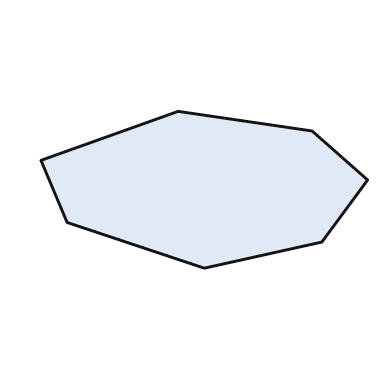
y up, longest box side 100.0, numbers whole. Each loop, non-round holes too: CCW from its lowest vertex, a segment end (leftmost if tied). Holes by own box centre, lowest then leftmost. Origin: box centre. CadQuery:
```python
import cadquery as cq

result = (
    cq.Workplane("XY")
    .moveTo(0.0, -24.0)
    .lineTo(36.0, -16.0)
    .lineTo(50.0, 3.0)
    .lineTo(33.0, 18.0)
    .lineTo(-8.0, 24.0)
    .lineTo(-50.0, 9.0)
    .lineTo(-42.0, -10.0)
    .close()
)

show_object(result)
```